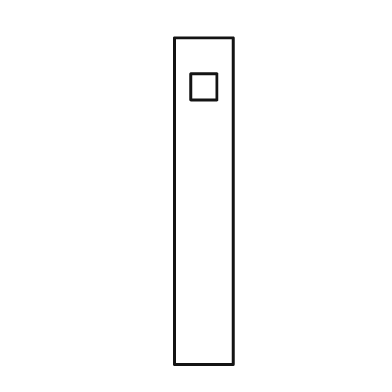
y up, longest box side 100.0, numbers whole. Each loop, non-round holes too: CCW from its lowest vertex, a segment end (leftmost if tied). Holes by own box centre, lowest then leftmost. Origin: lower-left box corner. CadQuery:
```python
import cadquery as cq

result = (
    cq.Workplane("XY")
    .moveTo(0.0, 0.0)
    .lineTo(18.0, 0.0)
    .lineTo(18.0, 100.0)
    .lineTo(0.0, 100.0)
    .close()
    .moveTo(5.0, 81.0)
    .lineTo(13.0, 81.0)
    .lineTo(13.0, 89.0)
    .lineTo(5.0, 89.0)
    .close()
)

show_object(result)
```